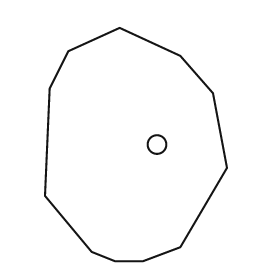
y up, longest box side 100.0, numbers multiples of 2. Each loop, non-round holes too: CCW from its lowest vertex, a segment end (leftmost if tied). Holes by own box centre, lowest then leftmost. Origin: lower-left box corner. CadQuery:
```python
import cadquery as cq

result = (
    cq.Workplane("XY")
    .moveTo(30.0, 0.0)
    .lineTo(42.0, 0.0)
    .lineTo(58.0, 6.0)
    .lineTo(78.0, 40.0)
    .lineTo(72.0, 72.0)
    .lineTo(58.0, 88.0)
    .lineTo(32.0, 100.0)
    .lineTo(10.0, 90.0)
    .lineTo(2.0, 74.0)
    .lineTo(0.0, 28.0)
    .lineTo(20.0, 4.0)
    .close()
    .moveTo(48.0, 50.0)
    .circle(4.0)
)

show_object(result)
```